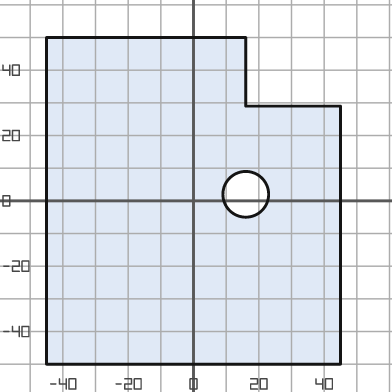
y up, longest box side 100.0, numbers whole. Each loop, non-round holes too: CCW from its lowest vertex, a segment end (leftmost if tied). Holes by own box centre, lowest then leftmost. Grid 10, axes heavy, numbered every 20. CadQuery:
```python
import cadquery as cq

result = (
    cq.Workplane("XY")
    .moveTo(-45.0, -50.0)
    .lineTo(45.0, -50.0)
    .lineTo(45.0, 29.0)
    .lineTo(16.0, 29.0)
    .lineTo(16.0, 50.0)
    .lineTo(-45.0, 50.0)
    .close()
    .moveTo(16.0, 2.0)
    .circle(7.0)
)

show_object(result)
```